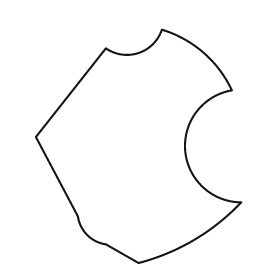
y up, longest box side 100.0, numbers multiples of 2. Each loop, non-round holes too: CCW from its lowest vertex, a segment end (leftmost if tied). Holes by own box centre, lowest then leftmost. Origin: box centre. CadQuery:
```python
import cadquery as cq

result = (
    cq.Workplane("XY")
    .moveTo(0.0, -50.0)
    .threePointArc((24.0, -40.0), (44.0, -24.0))
    .threePointArc((20.0, -2.0), (40.0, 24.0))
    .threePointArc((28.0, 40.0), (10.0, 50.0))
    .threePointArc((0.0, 40.0), (-14.0, 42.0))
    .lineTo(-44.0, 4.0)
    .lineTo(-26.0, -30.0)
    .threePointArc((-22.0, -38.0), (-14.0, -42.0))
    .close()
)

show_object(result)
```